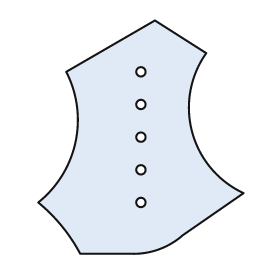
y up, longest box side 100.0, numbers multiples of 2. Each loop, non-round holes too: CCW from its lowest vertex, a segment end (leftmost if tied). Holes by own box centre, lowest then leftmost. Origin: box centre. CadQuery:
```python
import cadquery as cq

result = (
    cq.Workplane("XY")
    .moveTo(-26.0, -50.0)
    .lineTo(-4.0, -50.0)
    .threePointArc((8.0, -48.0), (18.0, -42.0))
    .lineTo(44.0, -24.0)
    .threePointArc((22.0, 2.0), (28.0, 36.0))
    .lineTo(6.0, 50.0)
    .lineTo(-32.0, 28.0)
    .threePointArc((-28.0, -2.0), (-44.0, -28.0))
    .threePointArc((-34.0, -38.0), (-26.0, -50.0))
    .close()
    .moveTo(0.0, -28.0)
    .circle(2.0)
    .moveTo(0.0, -14.0)
    .circle(2.0)
    .moveTo(0.0, 0.0)
    .circle(2.0)
    .moveTo(0.0, 14.0)
    .circle(2.0)
    .moveTo(0.0, 28.0)
    .circle(2.0)
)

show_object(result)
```